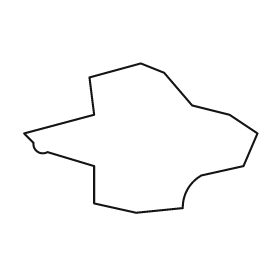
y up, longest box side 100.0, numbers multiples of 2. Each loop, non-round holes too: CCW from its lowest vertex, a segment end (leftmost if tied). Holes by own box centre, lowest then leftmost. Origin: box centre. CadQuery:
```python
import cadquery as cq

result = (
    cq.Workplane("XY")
    .moveTo(-2.0, -32.0)
    .lineTo(18.0, -30.0)
    .threePointArc((20.0, -22.0), (26.0, -16.0))
    .lineTo(44.0, -12.0)
    .lineTo(50.0, 2.0)
    .lineTo(38.0, 10.0)
    .lineTo(22.0, 14.0)
    .lineTo(10.0, 28.0)
    .lineTo(0.0, 32.0)
    .lineTo(-22.0, 26.0)
    .lineTo(-20.0, 10.0)
    .lineTo(-50.0, 2.0)
    .lineTo(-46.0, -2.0)
    .threePointArc((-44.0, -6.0), (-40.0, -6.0))
    .lineTo(-20.0, -12.0)
    .lineTo(-20.0, -28.0)
    .close()
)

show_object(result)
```